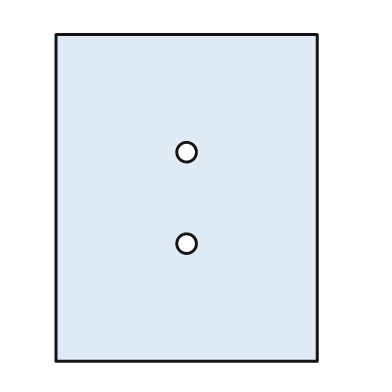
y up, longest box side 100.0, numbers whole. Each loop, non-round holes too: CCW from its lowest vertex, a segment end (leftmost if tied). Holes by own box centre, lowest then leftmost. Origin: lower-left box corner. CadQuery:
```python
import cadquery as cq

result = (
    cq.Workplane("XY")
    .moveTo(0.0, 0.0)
    .lineTo(80.0, 0.0)
    .lineTo(80.0, 100.0)
    .lineTo(0.0, 100.0)
    .close()
    .moveTo(40.0, 36.0)
    .circle(3.0)
    .moveTo(40.0, 64.0)
    .circle(3.0)
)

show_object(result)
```